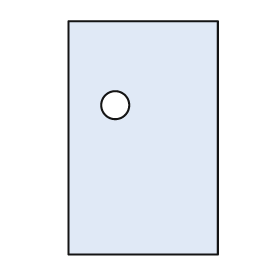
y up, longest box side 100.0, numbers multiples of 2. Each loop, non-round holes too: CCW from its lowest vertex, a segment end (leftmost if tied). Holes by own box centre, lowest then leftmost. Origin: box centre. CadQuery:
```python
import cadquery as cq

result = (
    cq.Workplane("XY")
    .moveTo(-32.0, -50.0)
    .lineTo(32.0, -50.0)
    .lineTo(32.0, 50.0)
    .lineTo(-32.0, 50.0)
    .close()
    .moveTo(-12.0, 14.0)
    .circle(6.0)
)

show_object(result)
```